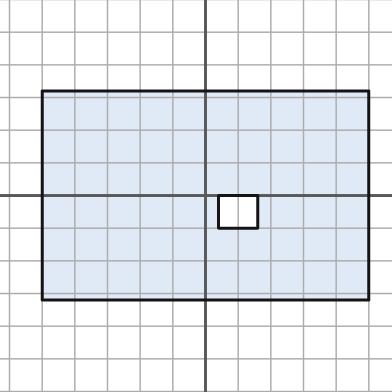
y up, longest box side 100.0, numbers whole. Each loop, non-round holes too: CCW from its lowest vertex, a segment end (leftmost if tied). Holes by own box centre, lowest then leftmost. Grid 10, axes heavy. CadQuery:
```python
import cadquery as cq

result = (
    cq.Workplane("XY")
    .moveTo(-50.0, -32.0)
    .lineTo(50.0, -32.0)
    .lineTo(50.0, 32.0)
    .lineTo(-50.0, 32.0)
    .close()
    .moveTo(4.0, -10.0)
    .lineTo(16.0, -10.0)
    .lineTo(16.0, 0.0)
    .lineTo(4.0, 0.0)
    .close()
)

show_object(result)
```